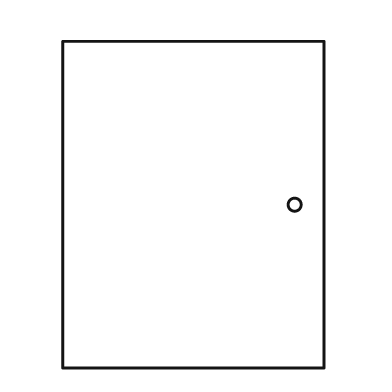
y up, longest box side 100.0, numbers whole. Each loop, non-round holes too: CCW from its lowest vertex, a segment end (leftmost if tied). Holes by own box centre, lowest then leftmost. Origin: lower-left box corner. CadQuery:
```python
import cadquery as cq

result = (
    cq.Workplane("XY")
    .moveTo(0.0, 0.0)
    .lineTo(80.0, 0.0)
    .lineTo(80.0, 100.0)
    .lineTo(0.0, 100.0)
    .close()
    .moveTo(71.0, 50.0)
    .circle(2.0)
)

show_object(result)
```